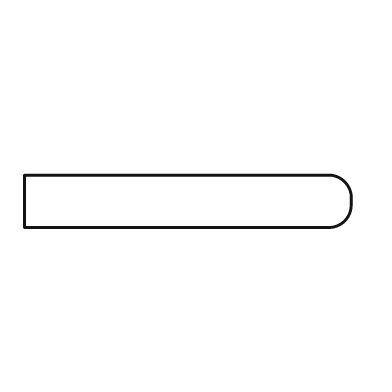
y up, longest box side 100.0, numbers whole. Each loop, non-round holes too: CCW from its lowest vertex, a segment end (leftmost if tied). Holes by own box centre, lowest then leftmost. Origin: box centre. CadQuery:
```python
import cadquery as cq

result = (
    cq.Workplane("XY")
    .moveTo(-50.0, -8.0)
    .lineTo(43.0, -8.0)
    .threePointArc((48.0, -6.0), (50.0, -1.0))
    .lineTo(50.0, 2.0)
    .threePointArc((48.0, 6.0), (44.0, 8.0))
    .lineTo(-50.0, 8.0)
    .close()
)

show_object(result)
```